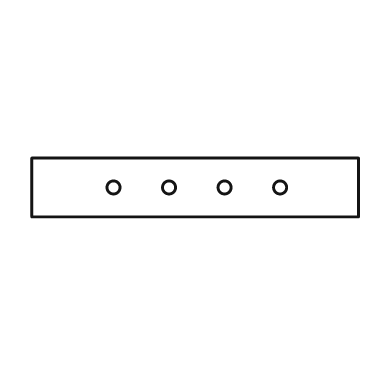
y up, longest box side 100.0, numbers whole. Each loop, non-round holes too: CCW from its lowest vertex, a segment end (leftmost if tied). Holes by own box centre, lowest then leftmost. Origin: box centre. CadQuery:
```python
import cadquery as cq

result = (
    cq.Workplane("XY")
    .moveTo(-50.0, -9.0)
    .lineTo(50.0, -9.0)
    .lineTo(50.0, 9.0)
    .lineTo(-50.0, 9.0)
    .close()
    .moveTo(-25.0, 0.0)
    .circle(2.0)
    .moveTo(-8.0, 0.0)
    .circle(2.0)
    .moveTo(9.0, 0.0)
    .circle(2.0)
    .moveTo(26.0, 0.0)
    .circle(2.0)
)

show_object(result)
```